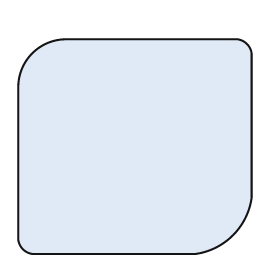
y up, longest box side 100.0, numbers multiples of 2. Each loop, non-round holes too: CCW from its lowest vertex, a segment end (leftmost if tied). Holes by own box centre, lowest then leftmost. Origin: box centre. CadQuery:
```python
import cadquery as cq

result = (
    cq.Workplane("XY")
    .moveTo(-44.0, -46.0)
    .lineTo(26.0, -46.0)
    .threePointArc((42.0, -38.0), (50.0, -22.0))
    .lineTo(50.0, 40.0)
    .threePointArc((48.0, 44.0), (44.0, 46.0))
    .lineTo(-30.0, 46.0)
    .threePointArc((-44.0, 40.0), (-50.0, 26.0))
    .lineTo(-50.0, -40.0)
    .threePointArc((-48.0, -44.0), (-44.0, -46.0))
    .close()
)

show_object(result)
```